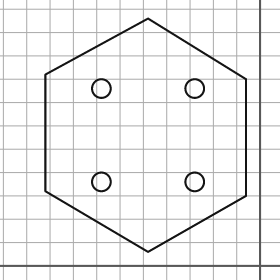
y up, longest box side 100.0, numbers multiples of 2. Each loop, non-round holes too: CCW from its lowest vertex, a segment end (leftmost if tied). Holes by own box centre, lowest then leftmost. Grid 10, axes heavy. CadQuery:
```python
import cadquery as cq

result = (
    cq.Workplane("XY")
    .moveTo(-48.0, 6.0)
    .lineTo(-6.0, 30.0)
    .lineTo(-6.0, 80.0)
    .lineTo(-48.0, 106.0)
    .lineTo(-92.0, 82.0)
    .lineTo(-92.0, 32.0)
    .close()
    .moveTo(-68.0, 36.0)
    .circle(4.0)
    .moveTo(-28.0, 36.0)
    .circle(4.0)
    .moveTo(-68.0, 76.0)
    .circle(4.0)
    .moveTo(-28.0, 76.0)
    .circle(4.0)
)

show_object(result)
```